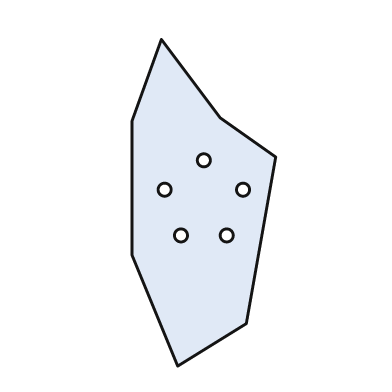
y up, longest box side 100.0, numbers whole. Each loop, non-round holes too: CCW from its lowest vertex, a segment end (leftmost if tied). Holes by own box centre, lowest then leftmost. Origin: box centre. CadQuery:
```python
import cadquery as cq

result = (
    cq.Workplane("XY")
    .moveTo(-8.0, -50.0)
    .lineTo(13.0, -37.0)
    .lineTo(22.0, 14.0)
    .lineTo(5.0, 26.0)
    .lineTo(-13.0, 50.0)
    .lineTo(-22.0, 25.0)
    .lineTo(-22.0, -16.0)
    .close()
    .moveTo(-7.0, -10.0)
    .circle(2.0)
    .moveTo(7.0, -10.0)
    .circle(2.0)
    .moveTo(-12.0, 4.0)
    .circle(2.0)
    .moveTo(12.0, 4.0)
    .circle(2.0)
    .moveTo(0.0, 13.0)
    .circle(2.0)
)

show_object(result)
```